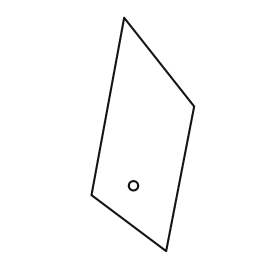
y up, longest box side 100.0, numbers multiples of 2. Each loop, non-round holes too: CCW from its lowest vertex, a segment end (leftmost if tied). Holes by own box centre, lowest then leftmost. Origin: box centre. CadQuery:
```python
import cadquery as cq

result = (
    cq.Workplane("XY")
    .moveTo(10.0, -50.0)
    .lineTo(22.0, 12.0)
    .lineTo(-8.0, 50.0)
    .lineTo(-22.0, -26.0)
    .close()
    .moveTo(-4.0, -22.0)
    .circle(2.0)
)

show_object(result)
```